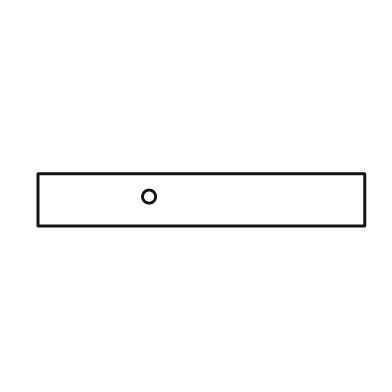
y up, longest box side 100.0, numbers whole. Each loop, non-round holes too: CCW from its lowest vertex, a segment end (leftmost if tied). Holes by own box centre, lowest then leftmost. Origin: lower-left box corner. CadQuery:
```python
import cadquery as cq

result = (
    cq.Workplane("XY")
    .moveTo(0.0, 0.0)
    .lineTo(100.0, 0.0)
    .lineTo(100.0, 16.0)
    .lineTo(0.0, 16.0)
    .close()
    .moveTo(34.0, 9.0)
    .circle(2.0)
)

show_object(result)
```